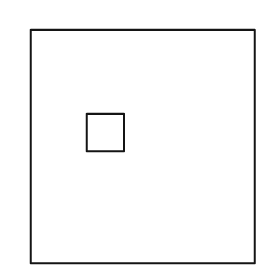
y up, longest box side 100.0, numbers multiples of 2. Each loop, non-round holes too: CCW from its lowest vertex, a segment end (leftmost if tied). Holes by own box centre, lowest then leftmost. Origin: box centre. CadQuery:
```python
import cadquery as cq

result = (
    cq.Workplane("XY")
    .moveTo(-48.0, -50.0)
    .lineTo(48.0, -50.0)
    .lineTo(48.0, 50.0)
    .lineTo(-48.0, 50.0)
    .close()
    .moveTo(-24.0, -2.0)
    .lineTo(-8.0, -2.0)
    .lineTo(-8.0, 14.0)
    .lineTo(-24.0, 14.0)
    .close()
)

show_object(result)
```